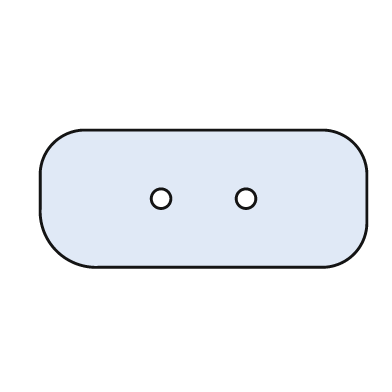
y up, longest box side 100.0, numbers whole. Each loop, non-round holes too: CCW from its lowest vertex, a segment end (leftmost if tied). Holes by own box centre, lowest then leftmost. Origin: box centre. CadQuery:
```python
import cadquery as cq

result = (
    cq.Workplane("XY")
    .moveTo(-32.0, -21.0)
    .lineTo(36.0, -21.0)
    .threePointArc((46.0, -17.0), (50.0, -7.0))
    .lineTo(50.0, 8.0)
    .threePointArc((46.0, 17.0), (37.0, 21.0))
    .lineTo(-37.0, 21.0)
    .threePointArc((-46.0, 17.0), (-50.0, 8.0))
    .lineTo(-50.0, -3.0)
    .threePointArc((-45.0, -16.0), (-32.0, -21.0))
    .close()
    .moveTo(-13.0, 0.0)
    .circle(3.0)
    .moveTo(13.0, 0.0)
    .circle(3.0)
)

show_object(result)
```